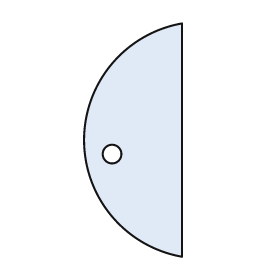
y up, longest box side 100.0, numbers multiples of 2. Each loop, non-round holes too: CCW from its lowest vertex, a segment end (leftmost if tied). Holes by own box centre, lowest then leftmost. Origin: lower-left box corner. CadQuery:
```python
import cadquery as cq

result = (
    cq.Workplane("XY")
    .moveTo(42.0, 0.0)
    .lineTo(42.0, 100.0)
    .threePointArc((0.0, 50.0), (42.0, 0.0))
    .close()
    .moveTo(12.0, 44.0)
    .circle(4.0)
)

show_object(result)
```